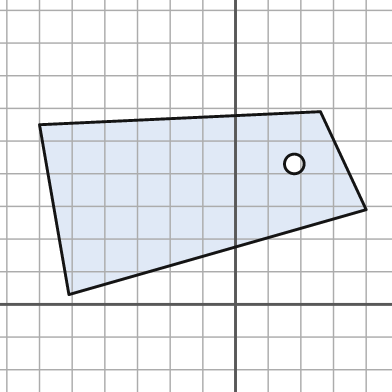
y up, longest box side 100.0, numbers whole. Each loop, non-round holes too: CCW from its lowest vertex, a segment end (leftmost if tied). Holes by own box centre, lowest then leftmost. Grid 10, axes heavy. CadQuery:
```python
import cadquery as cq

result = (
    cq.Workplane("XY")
    .moveTo(-51.0, 3.0)
    .lineTo(40.0, 29.0)
    .lineTo(26.0, 59.0)
    .lineTo(-60.0, 55.0)
    .close()
    .moveTo(18.0, 43.0)
    .circle(3.0)
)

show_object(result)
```